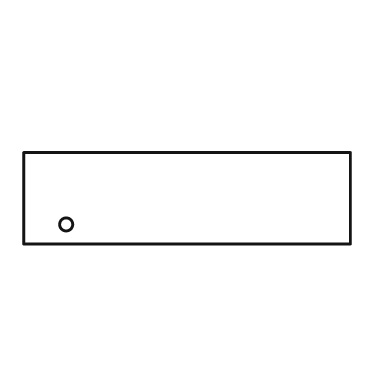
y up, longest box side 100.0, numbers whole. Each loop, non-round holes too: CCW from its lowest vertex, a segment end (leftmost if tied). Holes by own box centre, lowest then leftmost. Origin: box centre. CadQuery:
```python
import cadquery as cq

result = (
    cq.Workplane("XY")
    .moveTo(-50.0, -14.0)
    .lineTo(50.0, -14.0)
    .lineTo(50.0, 14.0)
    .lineTo(-50.0, 14.0)
    .close()
    .moveTo(-37.0, -8.0)
    .circle(2.0)
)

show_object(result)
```